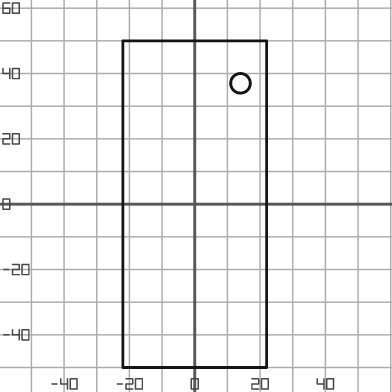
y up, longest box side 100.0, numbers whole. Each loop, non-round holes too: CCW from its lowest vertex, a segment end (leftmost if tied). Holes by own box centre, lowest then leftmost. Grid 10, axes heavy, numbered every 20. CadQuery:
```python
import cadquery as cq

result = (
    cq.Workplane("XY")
    .moveTo(-22.0, -50.0)
    .lineTo(22.0, -50.0)
    .lineTo(22.0, 50.0)
    .lineTo(-22.0, 50.0)
    .close()
    .moveTo(14.0, 37.0)
    .circle(3.0)
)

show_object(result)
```